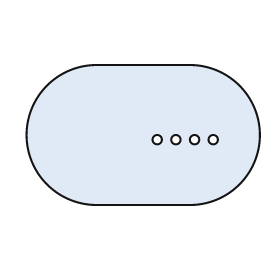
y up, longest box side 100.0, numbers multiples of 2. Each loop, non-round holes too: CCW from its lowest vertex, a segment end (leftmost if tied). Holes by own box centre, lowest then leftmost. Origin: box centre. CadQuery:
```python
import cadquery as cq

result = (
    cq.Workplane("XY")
    .moveTo(-20.0, -30.0)
    .lineTo(20.0, -30.0)
    .threePointArc((50.0, 0.0), (20.0, 30.0))
    .lineTo(-20.0, 30.0)
    .threePointArc((-50.0, 0.0), (-20.0, -30.0))
    .close()
    .moveTo(6.0, -2.0)
    .circle(2.0)
    .moveTo(14.0, -2.0)
    .circle(2.0)
    .moveTo(22.0, -2.0)
    .circle(2.0)
    .moveTo(30.0, -2.0)
    .circle(2.0)
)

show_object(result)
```